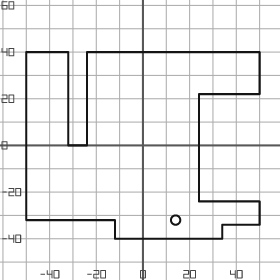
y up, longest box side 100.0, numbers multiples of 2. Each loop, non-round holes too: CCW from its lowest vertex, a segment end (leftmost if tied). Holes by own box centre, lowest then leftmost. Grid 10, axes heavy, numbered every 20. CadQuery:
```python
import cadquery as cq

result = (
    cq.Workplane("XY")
    .moveTo(-12.0, -40.0)
    .lineTo(34.0, -40.0)
    .lineTo(34.0, -34.0)
    .lineTo(50.0, -34.0)
    .lineTo(50.0, -24.0)
    .lineTo(24.0, -24.0)
    .lineTo(24.0, 22.0)
    .lineTo(50.0, 22.0)
    .lineTo(50.0, 40.0)
    .lineTo(-24.0, 40.0)
    .lineTo(-24.0, 0.0)
    .lineTo(-32.0, 0.0)
    .lineTo(-32.0, 40.0)
    .lineTo(-50.0, 40.0)
    .lineTo(-50.0, -32.0)
    .lineTo(-12.0, -32.0)
    .close()
    .moveTo(14.0, -32.0)
    .circle(2.0)
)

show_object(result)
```